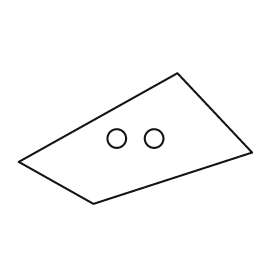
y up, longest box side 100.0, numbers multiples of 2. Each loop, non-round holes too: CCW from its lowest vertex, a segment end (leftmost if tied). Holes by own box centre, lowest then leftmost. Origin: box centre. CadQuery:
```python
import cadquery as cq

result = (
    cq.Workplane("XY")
    .moveTo(-18.0, -28.0)
    .lineTo(50.0, -6.0)
    .lineTo(18.0, 28.0)
    .lineTo(-50.0, -10.0)
    .close()
    .moveTo(-8.0, 0.0)
    .circle(4.0)
    .moveTo(8.0, 0.0)
    .circle(4.0)
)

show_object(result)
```